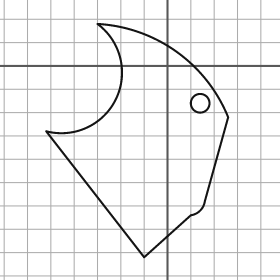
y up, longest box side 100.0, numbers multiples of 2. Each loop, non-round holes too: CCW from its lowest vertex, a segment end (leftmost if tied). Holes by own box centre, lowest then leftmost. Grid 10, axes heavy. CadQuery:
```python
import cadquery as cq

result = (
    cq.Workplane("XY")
    .moveTo(-10.0, -82.0)
    .lineTo(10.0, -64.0)
    .threePointArc((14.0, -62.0), (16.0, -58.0))
    .lineTo(26.0, -22.0)
    .threePointArc((4.0, 6.0), (-30.0, 18.0))
    .threePointArc((-22.0, -14.0), (-52.0, -28.0))
    .close()
    .moveTo(14.0, -16.0)
    .circle(4.0)
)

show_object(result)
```